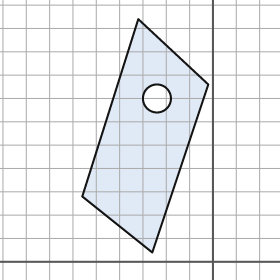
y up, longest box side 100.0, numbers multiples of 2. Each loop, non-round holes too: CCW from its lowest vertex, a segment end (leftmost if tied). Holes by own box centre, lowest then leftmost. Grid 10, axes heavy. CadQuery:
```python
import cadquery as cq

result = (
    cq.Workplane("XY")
    .moveTo(-26.0, 4.0)
    .lineTo(-2.0, 76.0)
    .lineTo(-32.0, 104.0)
    .lineTo(-56.0, 28.0)
    .close()
    .moveTo(-24.0, 70.0)
    .circle(6.0)
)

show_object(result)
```